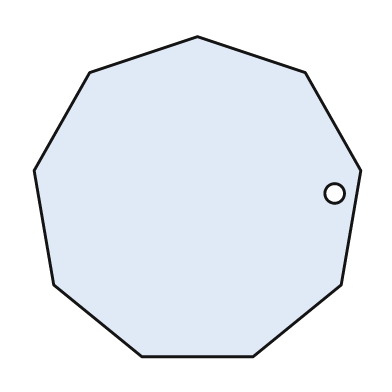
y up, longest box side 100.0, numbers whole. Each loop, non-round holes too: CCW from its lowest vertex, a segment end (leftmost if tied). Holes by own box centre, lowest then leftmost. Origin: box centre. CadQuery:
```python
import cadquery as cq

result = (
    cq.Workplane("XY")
    .moveTo(-17.0, -49.0)
    .lineTo(17.0, -49.0)
    .lineTo(44.0, -27.0)
    .lineTo(50.0, 8.0)
    .lineTo(33.0, 38.0)
    .lineTo(0.0, 49.0)
    .lineTo(-33.0, 38.0)
    .lineTo(-50.0, 8.0)
    .lineTo(-44.0, -27.0)
    .close()
    .moveTo(42.0, 1.0)
    .circle(3.0)
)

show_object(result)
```